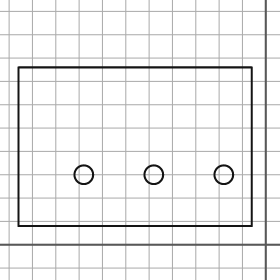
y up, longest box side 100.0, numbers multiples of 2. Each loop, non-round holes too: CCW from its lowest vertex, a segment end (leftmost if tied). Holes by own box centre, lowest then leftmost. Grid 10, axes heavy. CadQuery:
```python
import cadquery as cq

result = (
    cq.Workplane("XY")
    .moveTo(-106.0, 8.0)
    .lineTo(-6.0, 8.0)
    .lineTo(-6.0, 76.0)
    .lineTo(-106.0, 76.0)
    .close()
    .moveTo(-78.0, 30.0)
    .circle(4.0)
    .moveTo(-48.0, 30.0)
    .circle(4.0)
    .moveTo(-18.0, 30.0)
    .circle(4.0)
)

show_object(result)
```